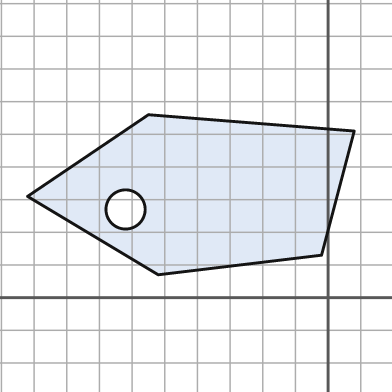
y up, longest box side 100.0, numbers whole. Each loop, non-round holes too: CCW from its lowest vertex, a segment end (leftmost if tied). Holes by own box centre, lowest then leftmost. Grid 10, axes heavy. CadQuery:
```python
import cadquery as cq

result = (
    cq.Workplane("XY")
    .moveTo(-52.0, 7.0)
    .lineTo(-2.0, 13.0)
    .lineTo(8.0, 51.0)
    .lineTo(-55.0, 56.0)
    .lineTo(-92.0, 31.0)
    .close()
    .moveTo(-62.0, 27.0)
    .circle(6.0)
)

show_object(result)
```